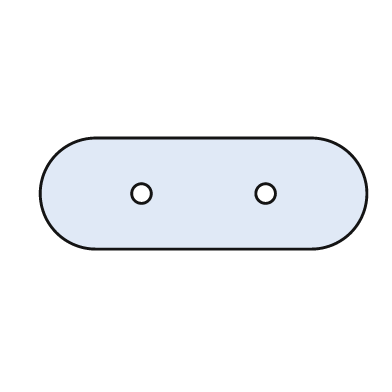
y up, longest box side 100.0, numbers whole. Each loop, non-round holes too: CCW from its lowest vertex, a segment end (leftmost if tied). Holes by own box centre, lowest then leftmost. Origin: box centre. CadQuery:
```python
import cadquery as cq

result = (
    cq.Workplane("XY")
    .moveTo(-33.0, -17.0)
    .lineTo(33.0, -17.0)
    .threePointArc((50.0, 0.0), (33.0, 17.0))
    .lineTo(-33.0, 17.0)
    .threePointArc((-50.0, 0.0), (-33.0, -17.0))
    .close()
    .moveTo(-19.0, 0.0)
    .circle(3.0)
    .moveTo(19.0, 0.0)
    .circle(3.0)
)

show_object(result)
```